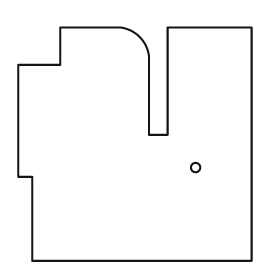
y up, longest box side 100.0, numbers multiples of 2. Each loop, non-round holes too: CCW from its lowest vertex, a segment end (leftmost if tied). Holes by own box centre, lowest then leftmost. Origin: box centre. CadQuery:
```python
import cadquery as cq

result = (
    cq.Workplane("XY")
    .moveTo(-44.0, -50.0)
    .lineTo(50.0, -50.0)
    .lineTo(50.0, 50.0)
    .lineTo(14.0, 50.0)
    .lineTo(14.0, 4.0)
    .lineTo(6.0, 4.0)
    .lineTo(6.0, 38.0)
    .threePointArc((2.0, 46.0), (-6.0, 50.0))
    .lineTo(-32.0, 50.0)
    .lineTo(-32.0, 34.0)
    .lineTo(-50.0, 34.0)
    .lineTo(-50.0, -14.0)
    .lineTo(-44.0, -14.0)
    .close()
    .moveTo(26.0, -10.0)
    .circle(2.0)
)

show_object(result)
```